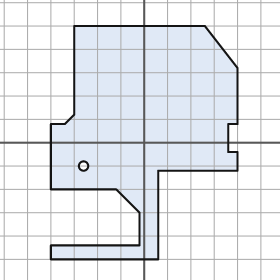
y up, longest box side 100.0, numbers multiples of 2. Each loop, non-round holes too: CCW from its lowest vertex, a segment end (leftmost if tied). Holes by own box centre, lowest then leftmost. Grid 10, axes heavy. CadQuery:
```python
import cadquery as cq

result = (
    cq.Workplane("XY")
    .moveTo(-40.0, -50.0)
    .lineTo(6.0, -50.0)
    .lineTo(6.0, -12.0)
    .lineTo(40.0, -12.0)
    .lineTo(40.0, -4.0)
    .lineTo(36.0, -4.0)
    .lineTo(36.0, 8.0)
    .lineTo(40.0, 8.0)
    .lineTo(40.0, 32.0)
    .lineTo(26.0, 50.0)
    .lineTo(-30.0, 50.0)
    .lineTo(-30.0, 12.0)
    .lineTo(-34.0, 8.0)
    .lineTo(-40.0, 8.0)
    .lineTo(-40.0, -20.0)
    .lineTo(-12.0, -20.0)
    .lineTo(-2.0, -30.0)
    .lineTo(-2.0, -44.0)
    .lineTo(-40.0, -44.0)
    .close()
    .moveTo(-26.0, -10.0)
    .circle(2.0)
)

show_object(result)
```